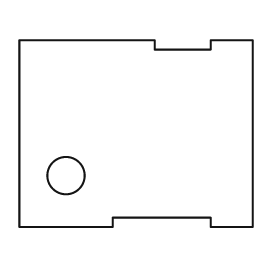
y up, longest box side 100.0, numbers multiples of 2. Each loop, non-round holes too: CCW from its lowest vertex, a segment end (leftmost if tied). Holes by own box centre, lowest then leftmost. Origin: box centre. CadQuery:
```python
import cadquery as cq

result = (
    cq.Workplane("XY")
    .moveTo(-50.0, -40.0)
    .lineTo(-10.0, -40.0)
    .lineTo(-10.0, -36.0)
    .lineTo(32.0, -36.0)
    .lineTo(32.0, -40.0)
    .lineTo(50.0, -40.0)
    .lineTo(50.0, 40.0)
    .lineTo(32.0, 40.0)
    .lineTo(32.0, 36.0)
    .lineTo(8.0, 36.0)
    .lineTo(8.0, 40.0)
    .lineTo(-50.0, 40.0)
    .close()
    .moveTo(-30.0, -18.0)
    .circle(8.0)
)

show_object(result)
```